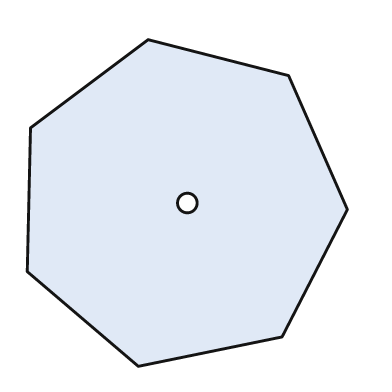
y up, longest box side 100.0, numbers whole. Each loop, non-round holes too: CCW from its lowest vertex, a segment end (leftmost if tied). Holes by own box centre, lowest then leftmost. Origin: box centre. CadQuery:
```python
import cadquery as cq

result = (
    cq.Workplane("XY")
    .moveTo(-15.0, -50.0)
    .lineTo(29.0, -41.0)
    .lineTo(49.0, -2.0)
    .lineTo(31.0, 39.0)
    .lineTo(-12.0, 50.0)
    .lineTo(-48.0, 23.0)
    .lineTo(-49.0, -21.0)
    .close()
    .moveTo(0.0, 0.0)
    .circle(3.0)
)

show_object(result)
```